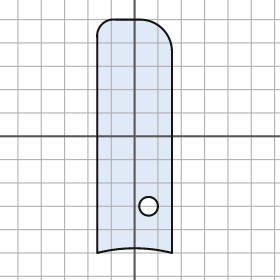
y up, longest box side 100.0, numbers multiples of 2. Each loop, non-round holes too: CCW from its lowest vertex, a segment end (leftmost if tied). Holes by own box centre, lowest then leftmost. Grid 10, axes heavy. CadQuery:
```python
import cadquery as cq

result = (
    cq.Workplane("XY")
    .moveTo(-16.0, -50.0)
    .threePointArc((0.0, -48.0), (16.0, -50.0))
    .lineTo(16.0, 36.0)
    .threePointArc((12.0, 46.0), (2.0, 50.0))
    .lineTo(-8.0, 50.0)
    .threePointArc((-14.0, 48.0), (-16.0, 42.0))
    .close()
    .moveTo(6.0, -30.0)
    .circle(4.0)
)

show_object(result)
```